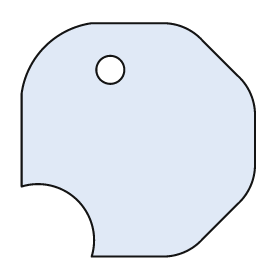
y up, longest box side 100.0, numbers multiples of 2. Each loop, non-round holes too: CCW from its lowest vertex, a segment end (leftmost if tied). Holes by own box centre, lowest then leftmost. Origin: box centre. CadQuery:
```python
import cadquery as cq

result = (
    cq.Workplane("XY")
    .moveTo(-20.0, -50.0)
    .lineTo(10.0, -50.0)
    .threePointArc((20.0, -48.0), (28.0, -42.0))
    .lineTo(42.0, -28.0)
    .threePointArc((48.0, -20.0), (50.0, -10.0))
    .lineTo(50.0, 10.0)
    .threePointArc((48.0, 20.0), (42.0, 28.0))
    .lineTo(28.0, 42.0)
    .threePointArc((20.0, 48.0), (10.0, 50.0))
    .lineTo(-20.0, 50.0)
    .threePointArc((-40.0, 40.0), (-50.0, 20.0))
    .lineTo(-50.0, -20.0)
    .threePointArc((-26.0, -26.0), (-20.0, -50.0))
    .close()
    .moveTo(-12.0, 30.0)
    .circle(6.0)
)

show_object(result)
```